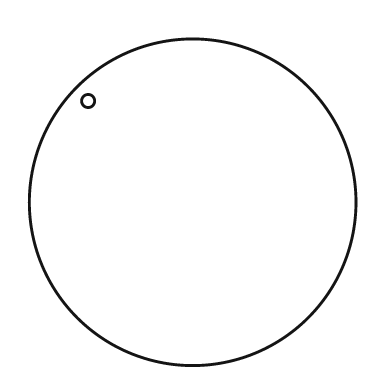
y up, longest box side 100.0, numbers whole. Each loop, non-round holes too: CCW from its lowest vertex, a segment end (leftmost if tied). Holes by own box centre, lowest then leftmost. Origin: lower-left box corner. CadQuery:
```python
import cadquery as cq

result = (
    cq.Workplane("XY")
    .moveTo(50.0, 50.0)
    .circle(50.0)
    .moveTo(18.0, 81.0)
    .circle(2.0)
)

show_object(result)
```